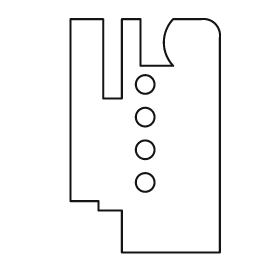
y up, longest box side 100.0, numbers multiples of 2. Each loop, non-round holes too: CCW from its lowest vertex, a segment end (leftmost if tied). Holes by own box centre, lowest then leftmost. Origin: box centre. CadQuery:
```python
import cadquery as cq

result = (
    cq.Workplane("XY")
    .moveTo(-10.0, -50.0)
    .lineTo(32.0, -50.0)
    .lineTo(32.0, 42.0)
    .threePointArc((30.0, 48.0), (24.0, 50.0))
    .lineTo(12.0, 50.0)
    .threePointArc((8.0, 40.0), (12.0, 30.0))
    .lineTo(-2.0, 30.0)
    .lineTo(-2.0, 50.0)
    .lineTo(-10.0, 50.0)
    .lineTo(-10.0, 16.0)
    .lineTo(-18.0, 16.0)
    .lineTo(-18.0, 50.0)
    .lineTo(-32.0, 50.0)
    .lineTo(-32.0, -28.0)
    .lineTo(-20.0, -28.0)
    .lineTo(-20.0, -32.0)
    .lineTo(-10.0, -32.0)
    .close()
    .moveTo(0.0, -20.0)
    .circle(4.0)
    .moveTo(0.0, -6.0)
    .circle(4.0)
    .moveTo(0.0, 8.0)
    .circle(4.0)
    .moveTo(0.0, 22.0)
    .circle(4.0)
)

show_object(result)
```